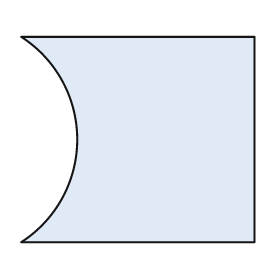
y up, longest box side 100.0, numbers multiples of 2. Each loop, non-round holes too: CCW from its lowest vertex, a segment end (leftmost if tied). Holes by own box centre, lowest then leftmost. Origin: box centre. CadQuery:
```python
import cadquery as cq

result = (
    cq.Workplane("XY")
    .moveTo(-50.0, -44.0)
    .lineTo(50.0, -44.0)
    .lineTo(50.0, 44.0)
    .lineTo(-50.0, 44.0)
    .threePointArc((-26.0, 0.0), (-50.0, -44.0))
    .close()
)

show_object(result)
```